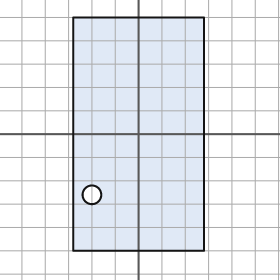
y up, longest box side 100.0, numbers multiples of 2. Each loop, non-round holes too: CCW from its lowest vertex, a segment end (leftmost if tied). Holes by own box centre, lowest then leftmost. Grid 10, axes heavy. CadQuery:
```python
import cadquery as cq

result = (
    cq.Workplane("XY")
    .moveTo(-28.0, -50.0)
    .lineTo(28.0, -50.0)
    .lineTo(28.0, 50.0)
    .lineTo(-28.0, 50.0)
    .close()
    .moveTo(-20.0, -26.0)
    .circle(4.0)
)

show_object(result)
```